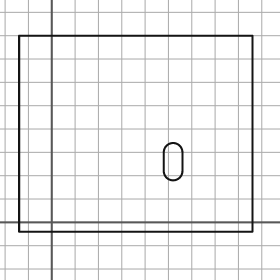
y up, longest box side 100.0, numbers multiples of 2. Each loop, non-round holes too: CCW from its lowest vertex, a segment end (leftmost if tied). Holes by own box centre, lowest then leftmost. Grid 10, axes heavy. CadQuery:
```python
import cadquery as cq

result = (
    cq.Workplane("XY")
    .moveTo(-14.0, -4.0)
    .lineTo(86.0, -4.0)
    .lineTo(86.0, 80.0)
    .lineTo(-14.0, 80.0)
    .close()
    .moveTo(48.0, 22.0)
    .threePointArc((52.0, 18.0), (56.0, 22.0))
    .lineTo(56.0, 30.0)
    .threePointArc((52.0, 34.0), (48.0, 30.0))
    .close()
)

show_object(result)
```